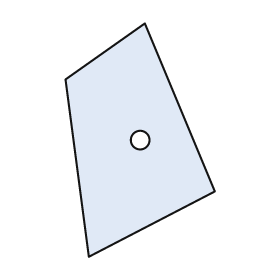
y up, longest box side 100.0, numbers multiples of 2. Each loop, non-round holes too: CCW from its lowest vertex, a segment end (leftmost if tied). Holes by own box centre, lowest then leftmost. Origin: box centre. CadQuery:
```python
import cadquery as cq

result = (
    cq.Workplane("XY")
    .moveTo(-22.0, -50.0)
    .lineTo(32.0, -22.0)
    .lineTo(2.0, 50.0)
    .lineTo(-32.0, 26.0)
    .close()
    .moveTo(0.0, 0.0)
    .circle(4.0)
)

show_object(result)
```